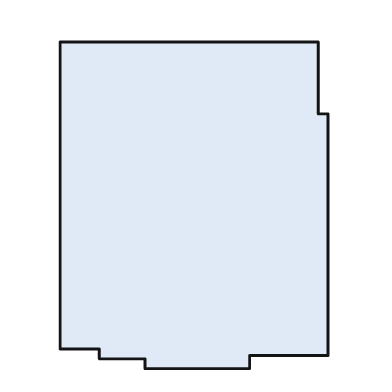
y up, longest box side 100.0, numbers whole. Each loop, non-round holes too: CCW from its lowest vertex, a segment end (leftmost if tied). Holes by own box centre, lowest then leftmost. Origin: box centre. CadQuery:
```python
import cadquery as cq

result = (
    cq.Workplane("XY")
    .moveTo(-15.0, -50.0)
    .lineTo(17.0, -50.0)
    .lineTo(17.0, -46.0)
    .lineTo(41.0, -46.0)
    .lineTo(41.0, 28.0)
    .lineTo(38.0, 28.0)
    .lineTo(38.0, 50.0)
    .lineTo(-41.0, 50.0)
    .lineTo(-41.0, -44.0)
    .lineTo(-29.0, -44.0)
    .lineTo(-29.0, -47.0)
    .lineTo(-15.0, -47.0)
    .close()
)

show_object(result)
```